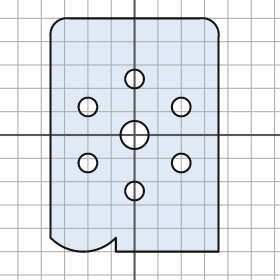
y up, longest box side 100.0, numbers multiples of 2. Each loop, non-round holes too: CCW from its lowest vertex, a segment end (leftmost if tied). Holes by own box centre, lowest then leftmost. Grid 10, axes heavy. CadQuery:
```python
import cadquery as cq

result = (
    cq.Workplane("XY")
    .moveTo(-8.0, -50.0)
    .lineTo(36.0, -50.0)
    .lineTo(36.0, 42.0)
    .threePointArc((34.0, 48.0), (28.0, 50.0))
    .lineTo(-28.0, 50.0)
    .threePointArc((-34.0, 48.0), (-36.0, 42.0))
    .lineTo(-36.0, -44.0)
    .threePointArc((-22.0, -50.0), (-8.0, -44.0))
    .close()
    .moveTo(0.0, -24.0)
    .circle(4.0)
    .moveTo(-20.0, -12.0)
    .circle(4.0)
    .moveTo(20.0, -12.0)
    .circle(4.0)
    .moveTo(0.0, 0.0)
    .circle(6.0)
    .moveTo(-20.0, 12.0)
    .circle(4.0)
    .moveTo(20.0, 12.0)
    .circle(4.0)
    .moveTo(0.0, 24.0)
    .circle(4.0)
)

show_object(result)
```